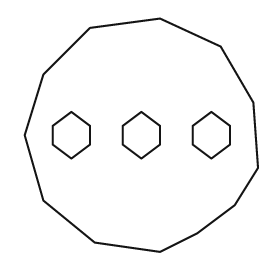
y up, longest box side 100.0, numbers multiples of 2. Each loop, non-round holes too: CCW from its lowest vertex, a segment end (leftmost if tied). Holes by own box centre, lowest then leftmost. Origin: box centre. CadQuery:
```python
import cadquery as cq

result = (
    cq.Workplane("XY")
    .moveTo(8.0, -50.0)
    .lineTo(24.0, -42.0)
    .lineTo(40.0, -30.0)
    .lineTo(50.0, -14.0)
    .lineTo(48.0, 14.0)
    .lineTo(34.0, 38.0)
    .lineTo(8.0, 50.0)
    .lineTo(-22.0, 46.0)
    .lineTo(-42.0, 26.0)
    .lineTo(-50.0, 0.0)
    .lineTo(-42.0, -28.0)
    .lineTo(-20.0, -46.0)
    .close()
    .moveTo(-30.0, -10.0)
    .lineTo(-22.0, -4.0)
    .lineTo(-22.0, 4.0)
    .lineTo(-30.0, 10.0)
    .lineTo(-38.0, 4.0)
    .lineTo(-38.0, -4.0)
    .close()
    .moveTo(0.0, -10.0)
    .lineTo(8.0, -4.0)
    .lineTo(8.0, 4.0)
    .lineTo(0.0, 10.0)
    .lineTo(-8.0, 4.0)
    .lineTo(-8.0, -4.0)
    .close()
    .moveTo(30.0, -10.0)
    .lineTo(38.0, -4.0)
    .lineTo(38.0, 4.0)
    .lineTo(30.0, 10.0)
    .lineTo(22.0, 4.0)
    .lineTo(22.0, -4.0)
    .close()
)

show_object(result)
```